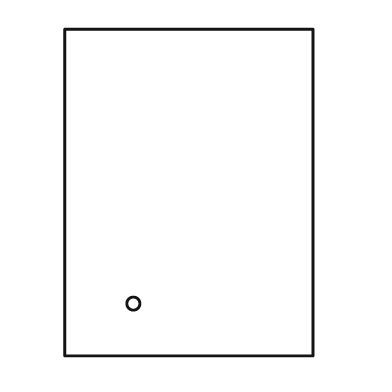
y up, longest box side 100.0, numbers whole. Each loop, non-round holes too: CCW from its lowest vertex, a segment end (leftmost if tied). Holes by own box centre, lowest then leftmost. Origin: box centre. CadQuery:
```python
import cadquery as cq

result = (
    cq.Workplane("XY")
    .moveTo(-38.0, -50.0)
    .lineTo(38.0, -50.0)
    .lineTo(38.0, 50.0)
    .lineTo(-38.0, 50.0)
    .close()
    .moveTo(-17.0, -34.0)
    .circle(2.0)
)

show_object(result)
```